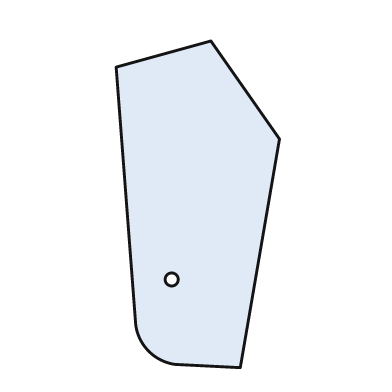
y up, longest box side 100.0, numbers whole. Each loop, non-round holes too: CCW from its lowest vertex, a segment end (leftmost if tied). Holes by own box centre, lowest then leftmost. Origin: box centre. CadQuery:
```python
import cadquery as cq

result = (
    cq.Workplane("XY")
    .moveTo(13.0, -50.0)
    .lineTo(25.0, 20.0)
    .lineTo(4.0, 50.0)
    .lineTo(-25.0, 42.0)
    .lineTo(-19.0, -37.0)
    .threePointArc((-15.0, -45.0), (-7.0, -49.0))
    .close()
    .moveTo(-8.0, -23.0)
    .circle(2.0)
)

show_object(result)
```